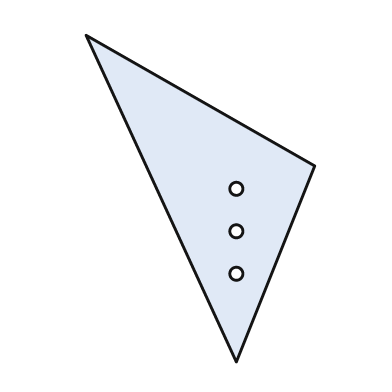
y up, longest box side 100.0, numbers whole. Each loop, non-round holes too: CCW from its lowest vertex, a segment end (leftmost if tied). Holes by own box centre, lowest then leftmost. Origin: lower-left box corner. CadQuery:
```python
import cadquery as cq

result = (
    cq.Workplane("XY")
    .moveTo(46.0, 0.0)
    .lineTo(70.0, 60.0)
    .lineTo(0.0, 100.0)
    .close()
    .moveTo(46.0, 27.0)
    .circle(2.0)
    .moveTo(46.0, 40.0)
    .circle(2.0)
    .moveTo(46.0, 53.0)
    .circle(2.0)
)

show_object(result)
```